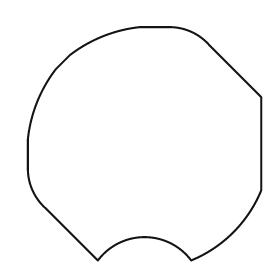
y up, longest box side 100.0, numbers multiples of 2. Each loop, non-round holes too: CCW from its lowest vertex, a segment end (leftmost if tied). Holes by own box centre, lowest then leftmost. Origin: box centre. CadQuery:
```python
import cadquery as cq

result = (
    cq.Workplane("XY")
    .moveTo(-20.0, -50.0)
    .threePointArc((0.0, -40.0), (20.0, -50.0))
    .threePointArc((38.0, -38.0), (50.0, -20.0))
    .lineTo(50.0, 20.0)
    .lineTo(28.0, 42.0)
    .threePointArc((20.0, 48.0), (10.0, 50.0))
    .lineTo(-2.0, 50.0)
    .threePointArc((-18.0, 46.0), (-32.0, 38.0))
    .lineTo(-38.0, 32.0)
    .threePointArc((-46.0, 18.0), (-50.0, 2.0))
    .lineTo(-50.0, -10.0)
    .threePointArc((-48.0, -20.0), (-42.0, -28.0))
    .close()
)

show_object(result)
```